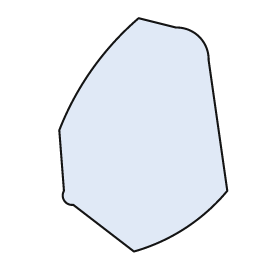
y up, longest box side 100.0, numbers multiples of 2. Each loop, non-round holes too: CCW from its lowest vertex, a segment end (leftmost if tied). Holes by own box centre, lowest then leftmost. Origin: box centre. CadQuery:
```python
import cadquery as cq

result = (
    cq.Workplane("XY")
    .moveTo(-4.0, -50.0)
    .threePointArc((18.0, -40.0), (36.0, -24.0))
    .lineTo(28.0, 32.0)
    .threePointArc((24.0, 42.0), (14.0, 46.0))
    .lineTo(-2.0, 50.0)
    .threePointArc((-22.0, 28.0), (-36.0, 2.0))
    .lineTo(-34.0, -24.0)
    .threePointArc((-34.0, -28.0), (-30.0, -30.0))
    .close()
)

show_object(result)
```